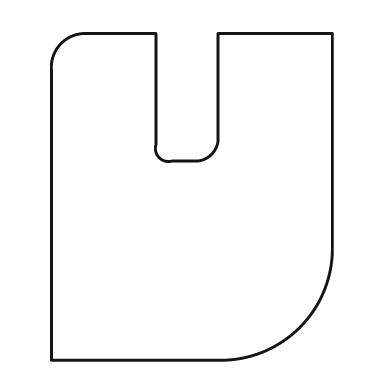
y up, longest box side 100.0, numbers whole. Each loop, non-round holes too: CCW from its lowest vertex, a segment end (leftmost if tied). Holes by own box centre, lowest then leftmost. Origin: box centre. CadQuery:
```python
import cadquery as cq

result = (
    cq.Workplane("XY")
    .moveTo(-43.0, -50.0)
    .lineTo(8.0, -50.0)
    .threePointArc((33.0, -40.0), (43.0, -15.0))
    .lineTo(43.0, 50.0)
    .lineTo(8.0, 50.0)
    .lineTo(8.0, 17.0)
    .threePointArc((6.0, 13.0), (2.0, 11.0))
    .lineTo(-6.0, 11.0)
    .threePointArc((-10.0, 12.0), (-11.0, 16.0))
    .lineTo(-11.0, 50.0)
    .lineTo(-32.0, 50.0)
    .threePointArc((-40.0, 47.0), (-43.0, 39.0))
    .close()
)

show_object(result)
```